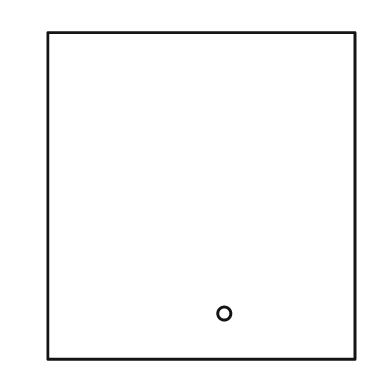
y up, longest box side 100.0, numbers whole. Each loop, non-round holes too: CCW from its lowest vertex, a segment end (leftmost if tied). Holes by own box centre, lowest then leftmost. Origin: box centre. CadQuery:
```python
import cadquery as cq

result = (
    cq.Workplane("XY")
    .moveTo(-47.0, -50.0)
    .lineTo(47.0, -50.0)
    .lineTo(47.0, 50.0)
    .lineTo(-47.0, 50.0)
    .close()
    .moveTo(7.0, -36.0)
    .circle(2.0)
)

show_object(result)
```